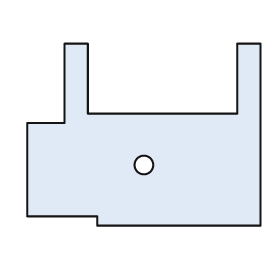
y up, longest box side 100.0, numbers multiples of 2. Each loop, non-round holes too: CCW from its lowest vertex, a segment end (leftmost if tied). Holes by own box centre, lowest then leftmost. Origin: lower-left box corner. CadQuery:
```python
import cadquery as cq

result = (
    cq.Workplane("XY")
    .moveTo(30.0, 0.0)
    .lineTo(100.0, 0.0)
    .lineTo(100.0, 78.0)
    .lineTo(90.0, 78.0)
    .lineTo(90.0, 48.0)
    .lineTo(26.0, 48.0)
    .lineTo(26.0, 78.0)
    .lineTo(16.0, 78.0)
    .lineTo(16.0, 44.0)
    .lineTo(0.0, 44.0)
    .lineTo(0.0, 4.0)
    .lineTo(30.0, 4.0)
    .close()
    .moveTo(50.0, 26.0)
    .circle(4.0)
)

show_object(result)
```